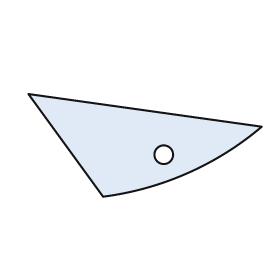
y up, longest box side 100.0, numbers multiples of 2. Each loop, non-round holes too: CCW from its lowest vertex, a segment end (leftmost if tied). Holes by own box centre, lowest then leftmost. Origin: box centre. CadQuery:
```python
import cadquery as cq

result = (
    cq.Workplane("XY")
    .moveTo(-18.0, -22.0)
    .threePointArc((18.0, -12.0), (50.0, 8.0))
    .lineTo(-50.0, 22.0)
    .close()
    .moveTo(8.0, -4.0)
    .circle(4.0)
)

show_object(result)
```